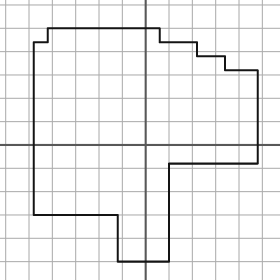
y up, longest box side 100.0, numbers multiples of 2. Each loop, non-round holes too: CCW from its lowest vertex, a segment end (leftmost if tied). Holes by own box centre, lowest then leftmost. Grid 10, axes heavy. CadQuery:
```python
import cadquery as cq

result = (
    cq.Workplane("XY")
    .moveTo(-12.0, -50.0)
    .lineTo(10.0, -50.0)
    .lineTo(10.0, -8.0)
    .lineTo(48.0, -8.0)
    .lineTo(48.0, 32.0)
    .lineTo(34.0, 32.0)
    .lineTo(34.0, 38.0)
    .lineTo(22.0, 38.0)
    .lineTo(22.0, 44.0)
    .lineTo(6.0, 44.0)
    .lineTo(6.0, 50.0)
    .lineTo(-42.0, 50.0)
    .lineTo(-42.0, 44.0)
    .lineTo(-48.0, 44.0)
    .lineTo(-48.0, -30.0)
    .lineTo(-12.0, -30.0)
    .close()
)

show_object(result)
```